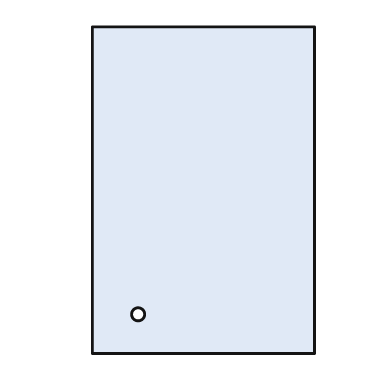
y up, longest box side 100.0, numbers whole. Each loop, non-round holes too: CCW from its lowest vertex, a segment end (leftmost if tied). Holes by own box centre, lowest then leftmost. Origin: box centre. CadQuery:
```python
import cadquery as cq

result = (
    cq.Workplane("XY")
    .moveTo(-34.0, -50.0)
    .lineTo(34.0, -50.0)
    .lineTo(34.0, 50.0)
    .lineTo(-34.0, 50.0)
    .close()
    .moveTo(-20.0, -38.0)
    .circle(2.0)
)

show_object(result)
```